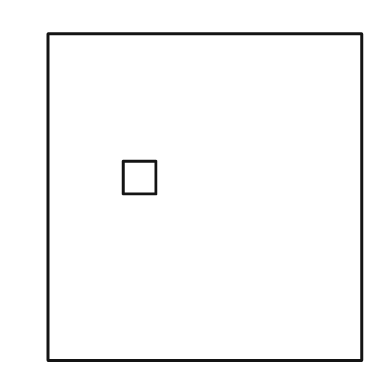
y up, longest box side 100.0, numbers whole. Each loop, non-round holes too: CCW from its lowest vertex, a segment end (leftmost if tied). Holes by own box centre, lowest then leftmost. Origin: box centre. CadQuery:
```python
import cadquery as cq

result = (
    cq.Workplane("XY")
    .moveTo(-48.0, -50.0)
    .lineTo(48.0, -50.0)
    .lineTo(48.0, 50.0)
    .lineTo(-48.0, 50.0)
    .close()
    .moveTo(-25.0, 1.0)
    .lineTo(-15.0, 1.0)
    .lineTo(-15.0, 11.0)
    .lineTo(-25.0, 11.0)
    .close()
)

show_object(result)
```